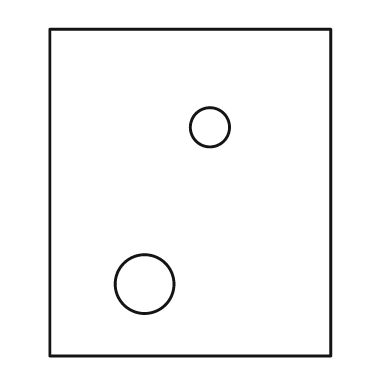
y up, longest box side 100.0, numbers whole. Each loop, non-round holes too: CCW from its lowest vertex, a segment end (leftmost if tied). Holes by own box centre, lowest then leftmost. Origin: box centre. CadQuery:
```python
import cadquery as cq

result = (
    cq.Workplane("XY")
    .moveTo(-43.0, -50.0)
    .lineTo(43.0, -50.0)
    .lineTo(43.0, 50.0)
    .lineTo(-43.0, 50.0)
    .close()
    .moveTo(-14.0, -28.0)
    .circle(9.0)
    .moveTo(6.0, 20.0)
    .circle(6.0)
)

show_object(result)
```